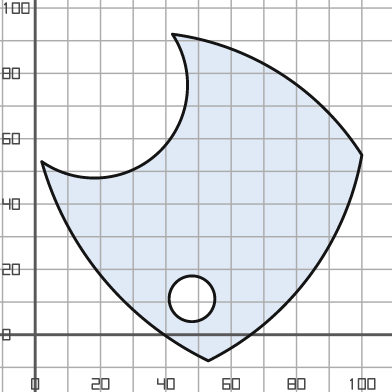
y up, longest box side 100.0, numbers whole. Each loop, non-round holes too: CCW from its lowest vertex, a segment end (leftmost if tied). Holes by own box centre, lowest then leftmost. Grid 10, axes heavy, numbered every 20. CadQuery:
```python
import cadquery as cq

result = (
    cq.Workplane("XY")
    .moveTo(53.0, -8.0)
    .threePointArc((84.0, 18.0), (100.0, 55.0))
    .threePointArc((75.0, 80.0), (42.0, 92.0))
    .threePointArc((38.0, 56.0), (2.0, 53.0))
    .threePointArc((21.0, 17.0), (53.0, -8.0))
    .close()
    .moveTo(48.0, 11.0)
    .circle(7.0)
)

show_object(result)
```